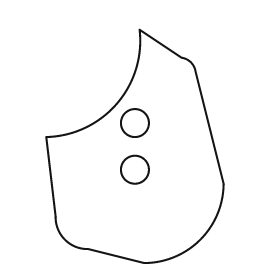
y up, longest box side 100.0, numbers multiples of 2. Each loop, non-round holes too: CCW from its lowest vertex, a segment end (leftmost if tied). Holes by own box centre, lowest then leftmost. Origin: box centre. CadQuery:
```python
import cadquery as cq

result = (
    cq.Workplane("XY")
    .moveTo(4.0, -50.0)
    .threePointArc((28.0, -40.0), (38.0, -16.0))
    .lineTo(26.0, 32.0)
    .threePointArc((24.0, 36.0), (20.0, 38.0))
    .lineTo(2.0, 50.0)
    .threePointArc((-8.0, 18.0), (-38.0, 4.0))
    .lineTo(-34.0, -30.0)
    .threePointArc((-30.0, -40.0), (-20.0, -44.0))
    .close()
    .moveTo(0.0, -10.0)
    .circle(6.0)
    .moveTo(0.0, 10.0)
    .circle(6.0)
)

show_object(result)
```